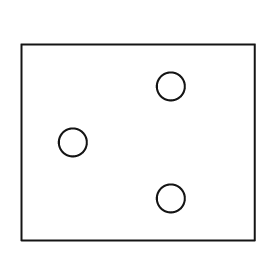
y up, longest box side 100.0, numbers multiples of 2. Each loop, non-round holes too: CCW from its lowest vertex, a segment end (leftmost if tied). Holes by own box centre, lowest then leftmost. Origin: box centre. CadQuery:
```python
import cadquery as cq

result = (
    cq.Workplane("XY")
    .moveTo(-50.0, -42.0)
    .lineTo(50.0, -42.0)
    .lineTo(50.0, 42.0)
    .lineTo(-50.0, 42.0)
    .close()
    .moveTo(14.0, -24.0)
    .circle(6.0)
    .moveTo(-28.0, 0.0)
    .circle(6.0)
    .moveTo(14.0, 24.0)
    .circle(6.0)
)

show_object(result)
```